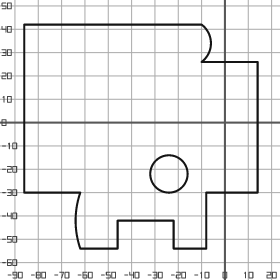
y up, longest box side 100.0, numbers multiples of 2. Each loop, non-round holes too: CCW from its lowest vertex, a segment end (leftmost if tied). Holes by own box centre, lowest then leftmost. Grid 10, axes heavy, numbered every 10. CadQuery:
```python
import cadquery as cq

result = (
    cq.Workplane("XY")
    .moveTo(-62.0, -54.0)
    .lineTo(-46.0, -54.0)
    .lineTo(-46.0, -42.0)
    .lineTo(-22.0, -42.0)
    .lineTo(-22.0, -54.0)
    .lineTo(-8.0, -54.0)
    .lineTo(-8.0, -30.0)
    .lineTo(14.0, -30.0)
    .lineTo(14.0, 26.0)
    .lineTo(-10.0, 26.0)
    .threePointArc((-6.0, 34.0), (-10.0, 42.0))
    .lineTo(-86.0, 42.0)
    .lineTo(-86.0, -30.0)
    .lineTo(-62.0, -30.0)
    .threePointArc((-64.0, -42.0), (-62.0, -54.0))
    .close()
    .moveTo(-24.0, -22.0)
    .circle(8.0)
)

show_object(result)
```